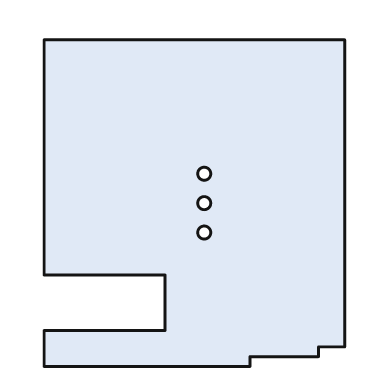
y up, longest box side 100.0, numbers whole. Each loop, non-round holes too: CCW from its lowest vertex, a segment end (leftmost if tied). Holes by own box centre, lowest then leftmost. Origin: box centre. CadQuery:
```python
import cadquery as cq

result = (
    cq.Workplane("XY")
    .moveTo(-46.0, -50.0)
    .lineTo(17.0, -50.0)
    .lineTo(17.0, -47.0)
    .lineTo(38.0, -47.0)
    .lineTo(38.0, -44.0)
    .lineTo(46.0, -44.0)
    .lineTo(46.0, 50.0)
    .lineTo(-46.0, 50.0)
    .lineTo(-46.0, -22.0)
    .lineTo(-9.0, -22.0)
    .lineTo(-9.0, -39.0)
    .lineTo(-46.0, -39.0)
    .close()
    .moveTo(3.0, -9.0)
    .circle(2.0)
    .moveTo(3.0, 0.0)
    .circle(2.0)
    .moveTo(3.0, 9.0)
    .circle(2.0)
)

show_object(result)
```